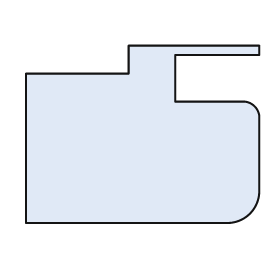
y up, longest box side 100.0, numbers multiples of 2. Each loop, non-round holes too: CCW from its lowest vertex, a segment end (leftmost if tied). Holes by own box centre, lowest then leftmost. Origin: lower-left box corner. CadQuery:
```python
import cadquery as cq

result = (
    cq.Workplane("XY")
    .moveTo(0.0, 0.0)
    .lineTo(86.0, 0.0)
    .threePointArc((96.0, 4.0), (100.0, 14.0))
    .lineTo(100.0, 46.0)
    .threePointArc((98.0, 50.0), (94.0, 52.0))
    .lineTo(64.0, 52.0)
    .lineTo(64.0, 72.0)
    .lineTo(100.0, 72.0)
    .lineTo(100.0, 76.0)
    .lineTo(44.0, 76.0)
    .lineTo(44.0, 64.0)
    .lineTo(0.0, 64.0)
    .close()
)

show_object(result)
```